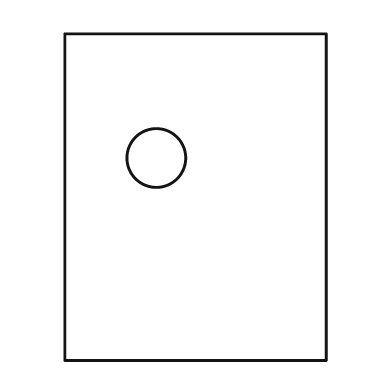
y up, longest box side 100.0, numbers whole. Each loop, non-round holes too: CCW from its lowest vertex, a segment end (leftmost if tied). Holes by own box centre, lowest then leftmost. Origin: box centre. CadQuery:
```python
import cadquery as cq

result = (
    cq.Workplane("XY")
    .moveTo(-40.0, -50.0)
    .lineTo(40.0, -50.0)
    .lineTo(40.0, 50.0)
    .lineTo(-40.0, 50.0)
    .close()
    .moveTo(-12.0, 12.0)
    .circle(9.0)
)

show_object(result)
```